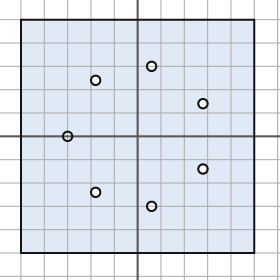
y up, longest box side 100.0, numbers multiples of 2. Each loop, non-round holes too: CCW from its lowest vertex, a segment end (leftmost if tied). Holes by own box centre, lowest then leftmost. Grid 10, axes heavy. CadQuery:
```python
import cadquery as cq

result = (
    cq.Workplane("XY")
    .moveTo(-50.0, -50.0)
    .lineTo(50.0, -50.0)
    .lineTo(50.0, 50.0)
    .lineTo(-50.0, 50.0)
    .close()
    .moveTo(6.0, -30.0)
    .circle(2.0)
    .moveTo(-18.0, -24.0)
    .circle(2.0)
    .moveTo(28.0, -14.0)
    .circle(2.0)
    .moveTo(-30.0, 0.0)
    .circle(2.0)
    .moveTo(28.0, 14.0)
    .circle(2.0)
    .moveTo(-18.0, 24.0)
    .circle(2.0)
    .moveTo(6.0, 30.0)
    .circle(2.0)
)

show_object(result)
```